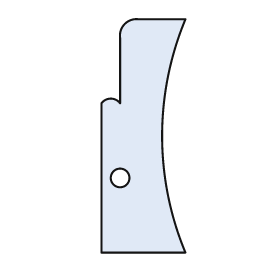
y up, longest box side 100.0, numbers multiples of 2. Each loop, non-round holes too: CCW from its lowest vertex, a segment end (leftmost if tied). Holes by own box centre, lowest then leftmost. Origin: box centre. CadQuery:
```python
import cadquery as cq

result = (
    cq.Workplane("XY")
    .moveTo(-18.0, -50.0)
    .lineTo(18.0, -50.0)
    .threePointArc((8.0, 0.0), (18.0, 50.0))
    .lineTo(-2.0, 50.0)
    .threePointArc((-8.0, 48.0), (-10.0, 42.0))
    .lineTo(-10.0, 14.0)
    .threePointArc((-14.0, 16.0), (-18.0, 14.0))
    .close()
    .moveTo(-10.0, -18.0)
    .circle(4.0)
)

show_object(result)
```